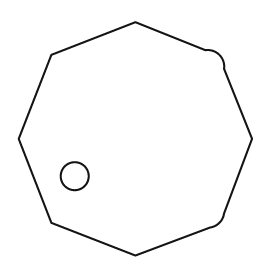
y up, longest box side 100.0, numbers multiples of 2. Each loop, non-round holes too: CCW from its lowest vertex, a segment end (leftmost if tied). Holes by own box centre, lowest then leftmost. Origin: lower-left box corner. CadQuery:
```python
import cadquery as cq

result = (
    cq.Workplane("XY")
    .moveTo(50.0, 0.0)
    .lineTo(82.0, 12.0)
    .threePointArc((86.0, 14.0), (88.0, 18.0))
    .lineTo(100.0, 50.0)
    .lineTo(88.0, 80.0)
    .threePointArc((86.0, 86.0), (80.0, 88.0))
    .lineTo(50.0, 100.0)
    .lineTo(14.0, 86.0)
    .lineTo(0.0, 50.0)
    .lineTo(14.0, 14.0)
    .close()
    .moveTo(24.0, 34.0)
    .circle(6.0)
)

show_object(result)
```